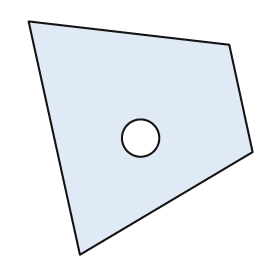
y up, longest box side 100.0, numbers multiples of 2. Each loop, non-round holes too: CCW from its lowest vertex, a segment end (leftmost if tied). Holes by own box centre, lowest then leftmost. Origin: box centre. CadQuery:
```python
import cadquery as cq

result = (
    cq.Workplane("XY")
    .moveTo(-26.0, -50.0)
    .lineTo(48.0, -6.0)
    .lineTo(38.0, 40.0)
    .lineTo(-48.0, 50.0)
    .close()
    .moveTo(0.0, 0.0)
    .circle(8.0)
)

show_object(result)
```